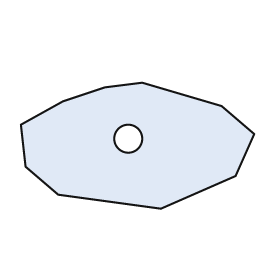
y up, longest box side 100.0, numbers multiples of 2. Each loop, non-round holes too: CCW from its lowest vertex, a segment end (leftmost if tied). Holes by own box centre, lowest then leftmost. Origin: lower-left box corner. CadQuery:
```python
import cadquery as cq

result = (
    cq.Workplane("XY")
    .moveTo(60.0, 0.0)
    .lineTo(92.0, 14.0)
    .lineTo(100.0, 32.0)
    .lineTo(86.0, 44.0)
    .lineTo(52.0, 54.0)
    .lineTo(36.0, 52.0)
    .lineTo(18.0, 46.0)
    .lineTo(0.0, 36.0)
    .lineTo(2.0, 18.0)
    .lineTo(16.0, 6.0)
    .close()
    .moveTo(46.0, 30.0)
    .circle(6.0)
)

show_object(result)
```